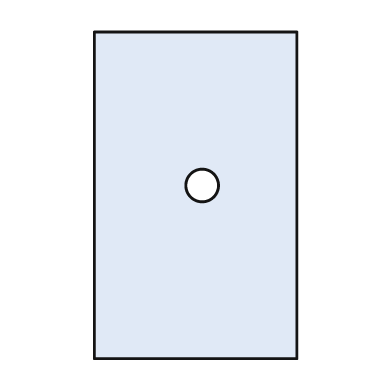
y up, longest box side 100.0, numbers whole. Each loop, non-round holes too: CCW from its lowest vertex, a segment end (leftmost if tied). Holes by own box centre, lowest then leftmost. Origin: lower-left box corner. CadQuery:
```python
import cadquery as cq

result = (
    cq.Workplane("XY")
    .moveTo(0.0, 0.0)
    .lineTo(62.0, 0.0)
    .lineTo(62.0, 100.0)
    .lineTo(0.0, 100.0)
    .close()
    .moveTo(33.0, 53.0)
    .circle(5.0)
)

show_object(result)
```